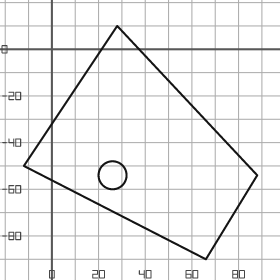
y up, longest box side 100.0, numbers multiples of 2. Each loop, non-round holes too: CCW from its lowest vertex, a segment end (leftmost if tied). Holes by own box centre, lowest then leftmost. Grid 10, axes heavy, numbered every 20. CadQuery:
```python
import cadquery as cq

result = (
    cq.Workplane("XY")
    .moveTo(66.0, -90.0)
    .lineTo(88.0, -54.0)
    .lineTo(28.0, 10.0)
    .lineTo(-12.0, -50.0)
    .close()
    .moveTo(26.0, -54.0)
    .circle(6.0)
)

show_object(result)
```